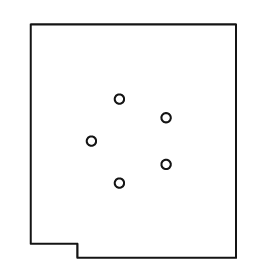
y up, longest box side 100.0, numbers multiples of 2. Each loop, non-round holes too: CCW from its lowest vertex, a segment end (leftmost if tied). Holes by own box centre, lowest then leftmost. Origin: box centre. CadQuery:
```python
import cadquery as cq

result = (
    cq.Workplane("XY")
    .moveTo(-24.0, -50.0)
    .lineTo(44.0, -50.0)
    .lineTo(44.0, 50.0)
    .lineTo(-44.0, 50.0)
    .lineTo(-44.0, -44.0)
    .lineTo(-24.0, -44.0)
    .close()
    .moveTo(-6.0, -18.0)
    .circle(2.0)
    .moveTo(14.0, -10.0)
    .circle(2.0)
    .moveTo(-18.0, 0.0)
    .circle(2.0)
    .moveTo(14.0, 10.0)
    .circle(2.0)
    .moveTo(-6.0, 18.0)
    .circle(2.0)
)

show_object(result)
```